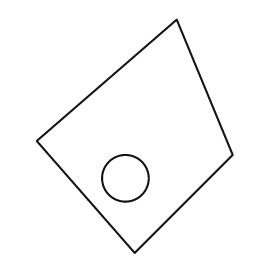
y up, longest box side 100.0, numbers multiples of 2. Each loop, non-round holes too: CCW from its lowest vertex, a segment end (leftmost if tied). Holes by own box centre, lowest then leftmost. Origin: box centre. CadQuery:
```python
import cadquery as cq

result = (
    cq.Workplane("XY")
    .moveTo(0.0, -50.0)
    .lineTo(42.0, -8.0)
    .lineTo(18.0, 50.0)
    .lineTo(-42.0, -2.0)
    .close()
    .moveTo(-4.0, -18.0)
    .circle(10.0)
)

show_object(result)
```